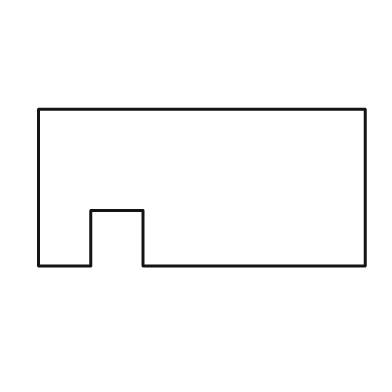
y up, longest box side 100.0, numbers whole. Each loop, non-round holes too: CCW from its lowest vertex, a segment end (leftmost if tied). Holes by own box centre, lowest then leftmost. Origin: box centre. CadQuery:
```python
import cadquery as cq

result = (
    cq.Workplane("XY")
    .moveTo(-50.0, -24.0)
    .lineTo(-34.0, -24.0)
    .lineTo(-34.0, -7.0)
    .lineTo(-18.0, -7.0)
    .lineTo(-18.0, -24.0)
    .lineTo(50.0, -24.0)
    .lineTo(50.0, 24.0)
    .lineTo(-50.0, 24.0)
    .close()
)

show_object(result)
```